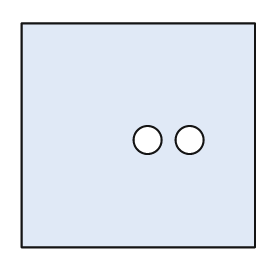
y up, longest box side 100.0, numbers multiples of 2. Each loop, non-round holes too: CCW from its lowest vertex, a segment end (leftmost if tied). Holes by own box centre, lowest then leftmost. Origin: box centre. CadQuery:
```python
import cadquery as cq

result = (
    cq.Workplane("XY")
    .moveTo(-50.0, -48.0)
    .lineTo(50.0, -48.0)
    .lineTo(50.0, 48.0)
    .lineTo(-50.0, 48.0)
    .close()
    .moveTo(4.0, -2.0)
    .circle(6.0)
    .moveTo(22.0, -2.0)
    .circle(6.0)
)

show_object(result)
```